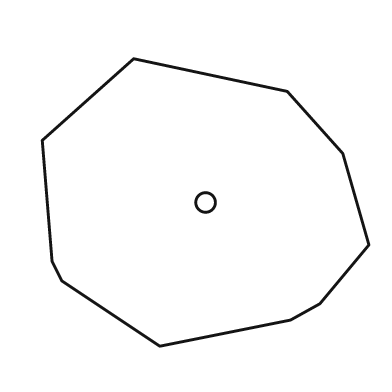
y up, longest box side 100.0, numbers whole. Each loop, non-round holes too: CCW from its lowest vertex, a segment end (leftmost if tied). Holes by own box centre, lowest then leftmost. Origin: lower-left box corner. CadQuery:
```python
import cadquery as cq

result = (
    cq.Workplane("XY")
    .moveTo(36.0, 0.0)
    .lineTo(76.0, 8.0)
    .lineTo(85.0, 13.0)
    .lineTo(100.0, 31.0)
    .lineTo(92.0, 59.0)
    .lineTo(75.0, 78.0)
    .lineTo(28.0, 88.0)
    .lineTo(0.0, 63.0)
    .lineTo(3.0, 26.0)
    .lineTo(6.0, 20.0)
    .close()
    .moveTo(50.0, 44.0)
    .circle(3.0)
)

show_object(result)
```